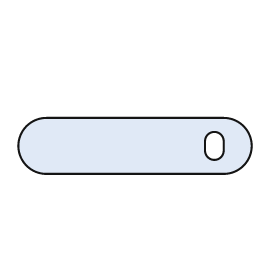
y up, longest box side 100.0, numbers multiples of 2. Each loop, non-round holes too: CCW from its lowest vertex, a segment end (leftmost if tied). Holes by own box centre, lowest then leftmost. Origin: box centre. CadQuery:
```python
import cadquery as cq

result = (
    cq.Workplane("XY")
    .moveTo(-38.0, -12.0)
    .lineTo(38.0, -12.0)
    .threePointArc((50.0, 0.0), (38.0, 12.0))
    .lineTo(-38.0, 12.0)
    .threePointArc((-50.0, 0.0), (-38.0, -12.0))
    .close()
    .moveTo(30.0, -2.0)
    .threePointArc((34.0, -6.0), (38.0, -2.0))
    .lineTo(38.0, 2.0)
    .threePointArc((34.0, 6.0), (30.0, 2.0))
    .close()
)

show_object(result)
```